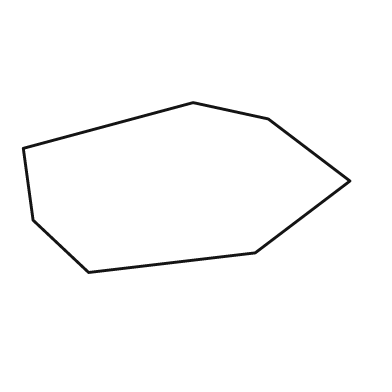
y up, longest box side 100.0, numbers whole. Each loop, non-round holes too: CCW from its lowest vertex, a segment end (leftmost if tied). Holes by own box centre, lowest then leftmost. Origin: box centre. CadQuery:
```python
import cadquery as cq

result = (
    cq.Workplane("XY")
    .moveTo(-30.0, -26.0)
    .lineTo(21.0, -20.0)
    .lineTo(50.0, 2.0)
    .lineTo(25.0, 21.0)
    .lineTo(2.0, 26.0)
    .lineTo(-50.0, 12.0)
    .lineTo(-47.0, -10.0)
    .close()
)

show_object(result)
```